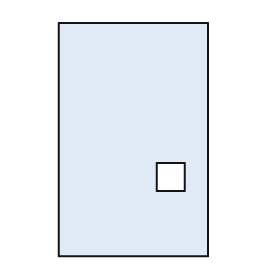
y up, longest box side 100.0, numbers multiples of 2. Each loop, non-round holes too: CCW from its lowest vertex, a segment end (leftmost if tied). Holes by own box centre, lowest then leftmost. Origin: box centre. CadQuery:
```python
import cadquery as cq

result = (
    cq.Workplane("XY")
    .moveTo(-32.0, -50.0)
    .lineTo(32.0, -50.0)
    .lineTo(32.0, 50.0)
    .lineTo(-32.0, 50.0)
    .close()
    .moveTo(10.0, -22.0)
    .lineTo(22.0, -22.0)
    .lineTo(22.0, -10.0)
    .lineTo(10.0, -10.0)
    .close()
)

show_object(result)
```